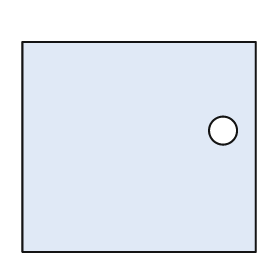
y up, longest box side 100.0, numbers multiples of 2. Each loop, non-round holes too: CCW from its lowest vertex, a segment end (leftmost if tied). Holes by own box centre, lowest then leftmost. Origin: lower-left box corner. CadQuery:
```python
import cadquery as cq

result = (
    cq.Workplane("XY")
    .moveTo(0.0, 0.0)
    .lineTo(100.0, 0.0)
    .lineTo(100.0, 90.0)
    .lineTo(0.0, 90.0)
    .close()
    .moveTo(86.0, 52.0)
    .circle(6.0)
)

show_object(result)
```